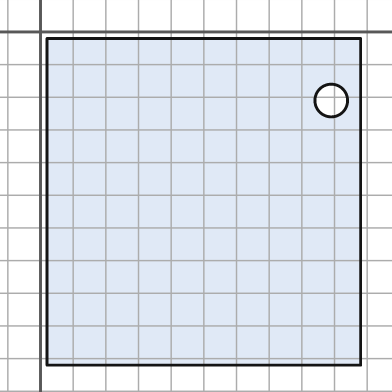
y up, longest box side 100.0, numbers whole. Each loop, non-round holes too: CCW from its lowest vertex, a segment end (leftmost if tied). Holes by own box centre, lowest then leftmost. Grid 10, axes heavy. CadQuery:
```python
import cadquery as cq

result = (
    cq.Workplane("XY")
    .moveTo(2.0, -102.0)
    .lineTo(98.0, -102.0)
    .lineTo(98.0, -2.0)
    .lineTo(2.0, -2.0)
    .close()
    .moveTo(89.0, -21.0)
    .circle(5.0)
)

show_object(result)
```